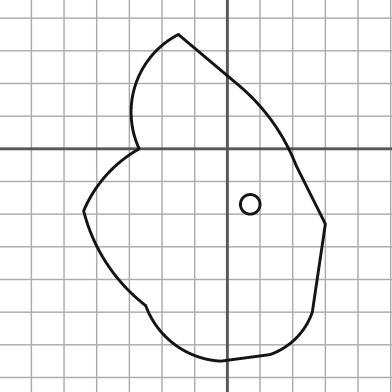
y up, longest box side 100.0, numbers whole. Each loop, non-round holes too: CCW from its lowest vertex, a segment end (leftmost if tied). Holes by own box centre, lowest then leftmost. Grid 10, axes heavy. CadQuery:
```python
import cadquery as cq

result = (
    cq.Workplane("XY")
    .moveTo(-2.0, -65.0)
    .lineTo(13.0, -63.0)
    .threePointArc((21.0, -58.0), (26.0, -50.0))
    .lineTo(30.0, -23.0)
    .lineTo(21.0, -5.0)
    .threePointArc((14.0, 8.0), (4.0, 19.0))
    .lineTo(-15.0, 35.0)
    .threePointArc((-28.0, 20.0), (-27.0, 0.0))
    .threePointArc((-37.0, -8.0), (-44.0, -19.0))
    .threePointArc((-37.0, -35.0), (-25.0, -48.0))
    .threePointArc((-16.0, -60.0), (-2.0, -65.0))
    .close()
    .moveTo(7.0, -17.0)
    .circle(3.0)
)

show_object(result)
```